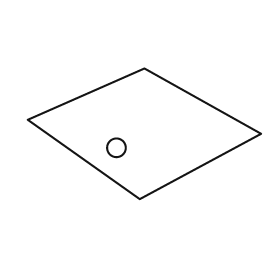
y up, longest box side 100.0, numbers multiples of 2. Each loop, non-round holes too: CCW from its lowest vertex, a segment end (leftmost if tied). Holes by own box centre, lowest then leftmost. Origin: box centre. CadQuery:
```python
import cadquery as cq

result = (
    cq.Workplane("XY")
    .moveTo(-2.0, -28.0)
    .lineTo(50.0, 0.0)
    .lineTo(0.0, 28.0)
    .lineTo(-50.0, 6.0)
    .close()
    .moveTo(-12.0, -6.0)
    .circle(4.0)
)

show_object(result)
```